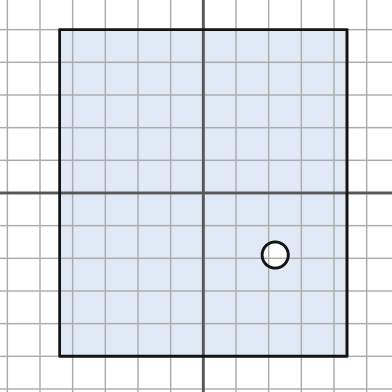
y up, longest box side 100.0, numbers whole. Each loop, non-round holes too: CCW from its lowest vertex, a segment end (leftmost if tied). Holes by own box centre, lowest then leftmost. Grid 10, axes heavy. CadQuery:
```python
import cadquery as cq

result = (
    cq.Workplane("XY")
    .moveTo(-44.0, -50.0)
    .lineTo(44.0, -50.0)
    .lineTo(44.0, 50.0)
    .lineTo(-44.0, 50.0)
    .close()
    .moveTo(22.0, -19.0)
    .circle(4.0)
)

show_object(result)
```